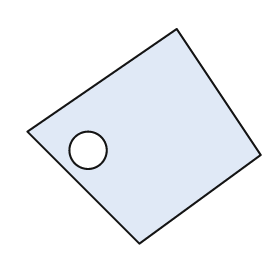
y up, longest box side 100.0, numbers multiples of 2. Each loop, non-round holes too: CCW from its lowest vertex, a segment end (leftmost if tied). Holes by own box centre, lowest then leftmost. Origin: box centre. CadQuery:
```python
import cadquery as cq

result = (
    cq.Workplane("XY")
    .moveTo(-2.0, -46.0)
    .lineTo(50.0, -8.0)
    .lineTo(14.0, 46.0)
    .lineTo(-50.0, 2.0)
    .close()
    .moveTo(-24.0, -6.0)
    .circle(8.0)
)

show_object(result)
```